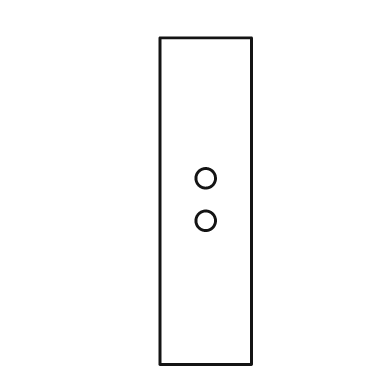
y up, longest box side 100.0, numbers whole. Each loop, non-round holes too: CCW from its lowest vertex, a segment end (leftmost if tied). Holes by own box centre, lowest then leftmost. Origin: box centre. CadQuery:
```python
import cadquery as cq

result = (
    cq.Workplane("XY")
    .moveTo(-14.0, -50.0)
    .lineTo(14.0, -50.0)
    .lineTo(14.0, 50.0)
    .lineTo(-14.0, 50.0)
    .close()
    .moveTo(0.0, -6.0)
    .circle(3.0)
    .moveTo(0.0, 7.0)
    .circle(3.0)
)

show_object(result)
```